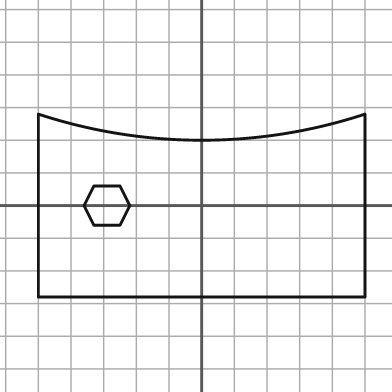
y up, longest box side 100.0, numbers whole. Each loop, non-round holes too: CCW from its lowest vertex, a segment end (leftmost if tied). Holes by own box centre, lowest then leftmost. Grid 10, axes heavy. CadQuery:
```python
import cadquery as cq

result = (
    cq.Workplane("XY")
    .moveTo(-50.0, -28.0)
    .lineTo(50.0, -28.0)
    .lineTo(50.0, 28.0)
    .threePointArc((0.0, 20.0), (-50.0, 28.0))
    .close()
    .moveTo(-33.0, -6.0)
    .lineTo(-25.0, -6.0)
    .lineTo(-22.0, 0.0)
    .lineTo(-25.0, 6.0)
    .lineTo(-33.0, 6.0)
    .lineTo(-36.0, 0.0)
    .close()
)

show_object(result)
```